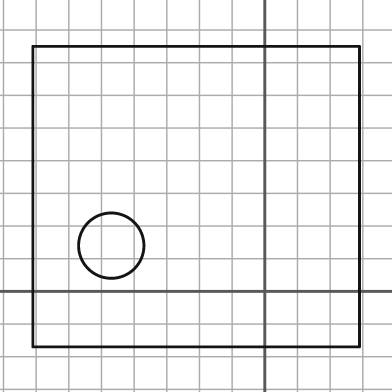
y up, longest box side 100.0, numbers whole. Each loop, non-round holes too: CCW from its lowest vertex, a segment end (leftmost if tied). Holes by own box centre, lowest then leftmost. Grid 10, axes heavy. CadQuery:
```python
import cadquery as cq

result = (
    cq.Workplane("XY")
    .moveTo(-71.0, -17.0)
    .lineTo(29.0, -17.0)
    .lineTo(29.0, 75.0)
    .lineTo(-71.0, 75.0)
    .close()
    .moveTo(-47.0, 14.0)
    .circle(10.0)
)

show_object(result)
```